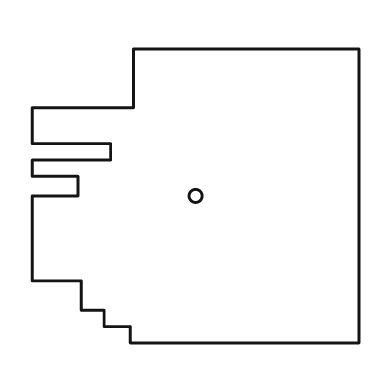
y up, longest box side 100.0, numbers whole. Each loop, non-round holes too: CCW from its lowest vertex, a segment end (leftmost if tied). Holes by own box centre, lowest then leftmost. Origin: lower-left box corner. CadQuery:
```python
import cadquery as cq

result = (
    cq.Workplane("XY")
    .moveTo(30.0, 0.0)
    .lineTo(100.0, 0.0)
    .lineTo(100.0, 90.0)
    .lineTo(31.0, 90.0)
    .lineTo(31.0, 72.0)
    .lineTo(0.0, 72.0)
    .lineTo(0.0, 61.0)
    .lineTo(24.0, 61.0)
    .lineTo(24.0, 56.0)
    .lineTo(0.0, 56.0)
    .lineTo(0.0, 51.0)
    .lineTo(14.0, 51.0)
    .lineTo(14.0, 45.0)
    .lineTo(0.0, 45.0)
    .lineTo(0.0, 19.0)
    .lineTo(15.0, 19.0)
    .lineTo(15.0, 10.0)
    .lineTo(22.0, 10.0)
    .lineTo(22.0, 5.0)
    .lineTo(30.0, 5.0)
    .close()
    .moveTo(50.0, 45.0)
    .circle(2.0)
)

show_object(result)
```